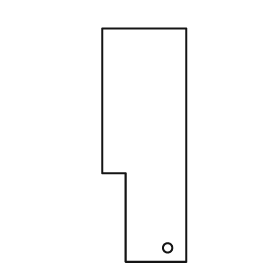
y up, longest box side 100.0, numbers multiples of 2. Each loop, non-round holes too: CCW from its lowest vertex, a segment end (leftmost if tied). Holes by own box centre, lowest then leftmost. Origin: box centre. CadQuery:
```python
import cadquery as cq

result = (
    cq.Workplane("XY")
    .moveTo(-8.0, -50.0)
    .lineTo(18.0, -50.0)
    .lineTo(18.0, 50.0)
    .lineTo(-18.0, 50.0)
    .lineTo(-18.0, -12.0)
    .lineTo(-8.0, -12.0)
    .close()
    .moveTo(10.0, -44.0)
    .circle(2.0)
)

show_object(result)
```